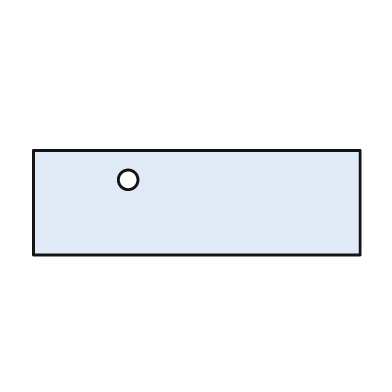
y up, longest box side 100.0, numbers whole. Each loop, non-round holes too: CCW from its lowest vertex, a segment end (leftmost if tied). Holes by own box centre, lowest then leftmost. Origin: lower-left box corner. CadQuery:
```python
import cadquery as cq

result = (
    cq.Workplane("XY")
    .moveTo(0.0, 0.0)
    .lineTo(100.0, 0.0)
    .lineTo(100.0, 32.0)
    .lineTo(0.0, 32.0)
    .close()
    .moveTo(29.0, 23.0)
    .circle(3.0)
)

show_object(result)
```